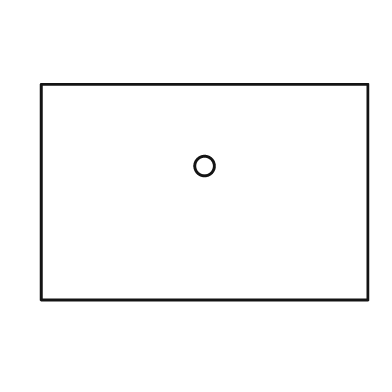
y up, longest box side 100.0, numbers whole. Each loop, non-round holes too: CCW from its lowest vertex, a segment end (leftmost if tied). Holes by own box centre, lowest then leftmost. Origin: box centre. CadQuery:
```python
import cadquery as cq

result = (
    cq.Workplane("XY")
    .moveTo(-50.0, -33.0)
    .lineTo(50.0, -33.0)
    .lineTo(50.0, 33.0)
    .lineTo(-50.0, 33.0)
    .close()
    .moveTo(0.0, 8.0)
    .circle(3.0)
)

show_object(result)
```